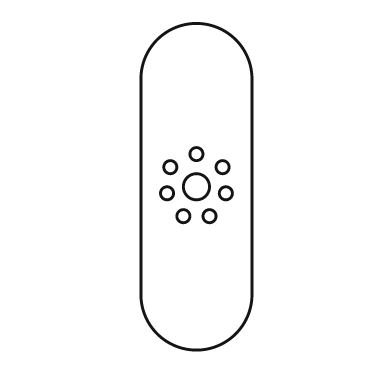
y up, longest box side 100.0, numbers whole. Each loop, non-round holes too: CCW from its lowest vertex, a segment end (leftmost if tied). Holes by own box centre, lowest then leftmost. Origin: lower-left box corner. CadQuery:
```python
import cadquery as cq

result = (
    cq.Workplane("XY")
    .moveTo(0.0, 17.0)
    .threePointArc((17.0, 0.0), (34.0, 17.0))
    .lineTo(34.0, 83.0)
    .threePointArc((17.0, 100.0), (0.0, 83.0))
    .close()
    .moveTo(13.0, 41.0)
    .circle(2.0)
    .moveTo(21.0, 41.0)
    .circle(2.0)
    .moveTo(8.0, 48.0)
    .circle(2.0)
    .moveTo(26.0, 48.0)
    .circle(2.0)
    .moveTo(17.0, 50.0)
    .circle(4.0)
    .moveTo(9.0, 56.0)
    .circle(2.0)
    .moveTo(25.0, 56.0)
    .circle(2.0)
    .moveTo(17.0, 60.0)
    .circle(2.0)
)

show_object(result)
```